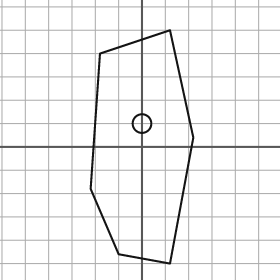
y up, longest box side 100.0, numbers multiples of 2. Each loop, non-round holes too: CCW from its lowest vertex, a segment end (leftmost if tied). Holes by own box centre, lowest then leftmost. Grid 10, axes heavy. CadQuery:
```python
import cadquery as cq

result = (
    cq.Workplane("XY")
    .moveTo(12.0, -50.0)
    .lineTo(22.0, 4.0)
    .lineTo(12.0, 50.0)
    .lineTo(-18.0, 40.0)
    .lineTo(-22.0, -18.0)
    .lineTo(-10.0, -46.0)
    .close()
    .moveTo(0.0, 10.0)
    .circle(4.0)
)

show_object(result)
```